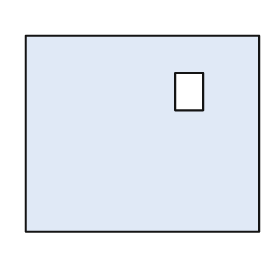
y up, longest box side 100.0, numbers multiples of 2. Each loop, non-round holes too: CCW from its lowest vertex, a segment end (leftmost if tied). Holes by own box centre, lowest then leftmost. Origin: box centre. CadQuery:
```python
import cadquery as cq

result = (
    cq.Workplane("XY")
    .moveTo(-50.0, -42.0)
    .lineTo(50.0, -42.0)
    .lineTo(50.0, 42.0)
    .lineTo(-50.0, 42.0)
    .close()
    .moveTo(14.0, 10.0)
    .lineTo(26.0, 10.0)
    .lineTo(26.0, 26.0)
    .lineTo(14.0, 26.0)
    .close()
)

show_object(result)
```